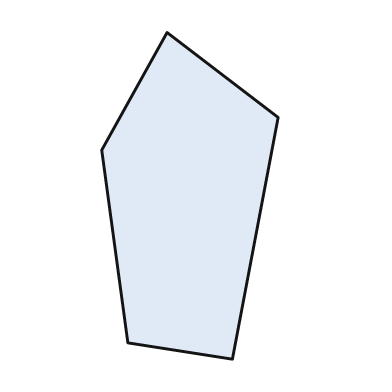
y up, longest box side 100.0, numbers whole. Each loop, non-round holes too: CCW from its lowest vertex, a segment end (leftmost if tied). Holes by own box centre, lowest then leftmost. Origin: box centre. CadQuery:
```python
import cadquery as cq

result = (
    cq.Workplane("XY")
    .moveTo(13.0, -50.0)
    .lineTo(27.0, 24.0)
    .lineTo(-7.0, 50.0)
    .lineTo(-27.0, 14.0)
    .lineTo(-19.0, -45.0)
    .close()
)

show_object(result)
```